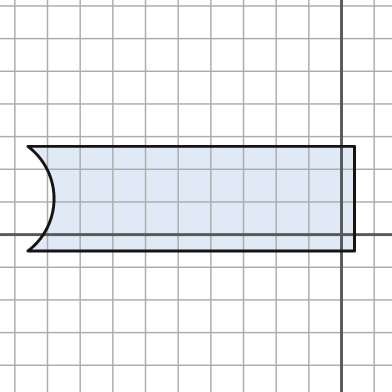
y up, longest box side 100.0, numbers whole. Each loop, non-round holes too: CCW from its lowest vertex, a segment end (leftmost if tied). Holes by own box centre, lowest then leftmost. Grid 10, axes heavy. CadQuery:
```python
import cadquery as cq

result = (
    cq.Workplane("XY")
    .moveTo(-96.0, -5.0)
    .lineTo(4.0, -5.0)
    .lineTo(4.0, 27.0)
    .lineTo(-96.0, 27.0)
    .threePointArc((-88.0, 11.0), (-96.0, -5.0))
    .close()
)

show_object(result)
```